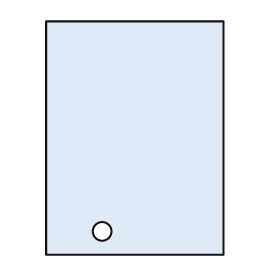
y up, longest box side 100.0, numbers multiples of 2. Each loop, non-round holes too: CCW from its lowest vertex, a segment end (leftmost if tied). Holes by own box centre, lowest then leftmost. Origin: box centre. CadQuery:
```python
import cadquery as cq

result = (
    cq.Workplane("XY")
    .moveTo(-38.0, -50.0)
    .lineTo(38.0, -50.0)
    .lineTo(38.0, 50.0)
    .lineTo(-38.0, 50.0)
    .close()
    .moveTo(-14.0, -40.0)
    .circle(4.0)
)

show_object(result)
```